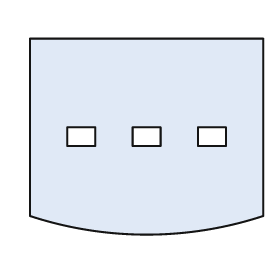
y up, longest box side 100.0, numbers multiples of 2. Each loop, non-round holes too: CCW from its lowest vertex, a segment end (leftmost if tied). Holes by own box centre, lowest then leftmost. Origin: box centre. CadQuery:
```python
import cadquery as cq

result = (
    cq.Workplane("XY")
    .moveTo(-50.0, -34.0)
    .threePointArc((0.0, -42.0), (50.0, -34.0))
    .lineTo(50.0, 42.0)
    .lineTo(-50.0, 42.0)
    .close()
    .moveTo(-34.0, -4.0)
    .lineTo(-22.0, -4.0)
    .lineTo(-22.0, 4.0)
    .lineTo(-34.0, 4.0)
    .close()
    .moveTo(-6.0, -4.0)
    .lineTo(6.0, -4.0)
    .lineTo(6.0, 4.0)
    .lineTo(-6.0, 4.0)
    .close()
    .moveTo(22.0, -4.0)
    .lineTo(34.0, -4.0)
    .lineTo(34.0, 4.0)
    .lineTo(22.0, 4.0)
    .close()
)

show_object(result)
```